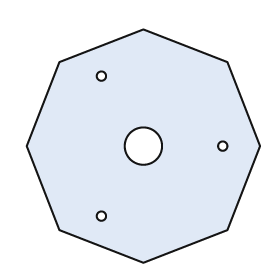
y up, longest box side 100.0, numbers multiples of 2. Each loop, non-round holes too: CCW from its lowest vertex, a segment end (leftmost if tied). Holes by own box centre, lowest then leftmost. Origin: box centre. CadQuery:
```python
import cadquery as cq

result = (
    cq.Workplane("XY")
    .moveTo(0.0, -50.0)
    .lineTo(36.0, -36.0)
    .lineTo(50.0, 0.0)
    .lineTo(36.0, 36.0)
    .lineTo(0.0, 50.0)
    .lineTo(-36.0, 36.0)
    .lineTo(-50.0, 0.0)
    .lineTo(-36.0, -36.0)
    .close()
    .moveTo(-18.0, -30.0)
    .circle(2.0)
    .moveTo(0.0, 0.0)
    .circle(8.0)
    .moveTo(34.0, 0.0)
    .circle(2.0)
    .moveTo(-18.0, 30.0)
    .circle(2.0)
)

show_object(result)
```